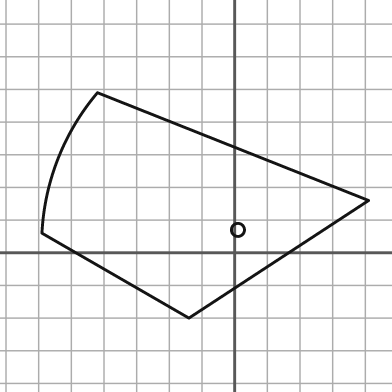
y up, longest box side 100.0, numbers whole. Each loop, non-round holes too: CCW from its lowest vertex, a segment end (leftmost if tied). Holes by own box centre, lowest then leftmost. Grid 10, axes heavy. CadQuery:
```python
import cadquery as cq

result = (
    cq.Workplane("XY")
    .moveTo(-14.0, -20.0)
    .lineTo(41.0, 16.0)
    .lineTo(-42.0, 49.0)
    .threePointArc((-54.0, 29.0), (-59.0, 6.0))
    .close()
    .moveTo(1.0, 7.0)
    .circle(2.0)
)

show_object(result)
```